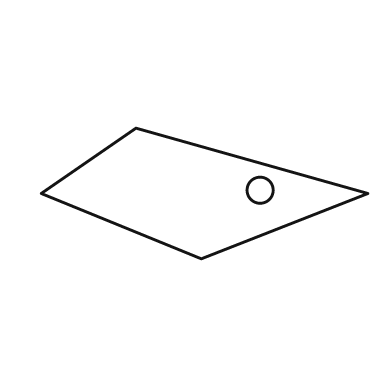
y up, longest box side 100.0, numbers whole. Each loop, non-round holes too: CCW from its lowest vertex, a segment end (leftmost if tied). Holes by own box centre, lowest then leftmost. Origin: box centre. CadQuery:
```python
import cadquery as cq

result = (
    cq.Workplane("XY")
    .moveTo(-1.0, -20.0)
    .lineTo(50.0, 0.0)
    .lineTo(-21.0, 20.0)
    .lineTo(-50.0, 0.0)
    .close()
    .moveTo(17.0, 1.0)
    .circle(4.0)
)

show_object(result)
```